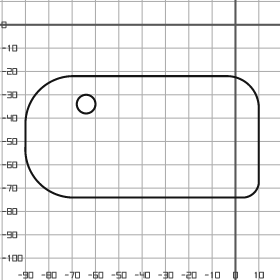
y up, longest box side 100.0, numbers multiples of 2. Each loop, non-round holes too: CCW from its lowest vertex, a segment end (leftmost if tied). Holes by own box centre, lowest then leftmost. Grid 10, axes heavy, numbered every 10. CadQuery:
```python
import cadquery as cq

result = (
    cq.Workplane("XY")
    .moveTo(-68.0, -74.0)
    .lineTo(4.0, -74.0)
    .threePointArc((8.0, -72.0), (10.0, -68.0))
    .lineTo(10.0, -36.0)
    .threePointArc((6.0, -26.0), (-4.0, -22.0))
    .lineTo(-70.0, -22.0)
    .threePointArc((-84.0, -28.0), (-90.0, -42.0))
    .lineTo(-90.0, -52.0)
    .threePointArc((-84.0, -68.0), (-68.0, -74.0))
    .close()
    .moveTo(-64.0, -34.0)
    .circle(4.0)
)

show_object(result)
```